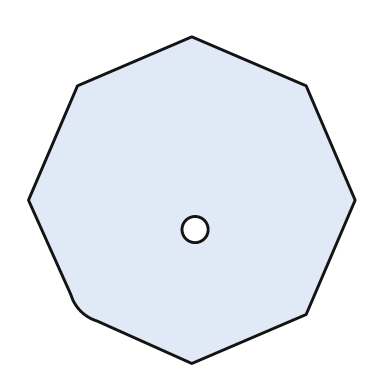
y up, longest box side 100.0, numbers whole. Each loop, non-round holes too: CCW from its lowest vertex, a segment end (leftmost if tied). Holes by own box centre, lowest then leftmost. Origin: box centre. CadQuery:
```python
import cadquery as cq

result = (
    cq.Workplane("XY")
    .moveTo(0.0, -50.0)
    .lineTo(35.0, -35.0)
    .lineTo(50.0, 0.0)
    .lineTo(35.0, 35.0)
    .lineTo(0.0, 50.0)
    .lineTo(-35.0, 35.0)
    .lineTo(-50.0, 0.0)
    .lineTo(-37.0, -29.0)
    .threePointArc((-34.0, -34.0), (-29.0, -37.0))
    .close()
    .moveTo(1.0, -9.0)
    .circle(4.0)
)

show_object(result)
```